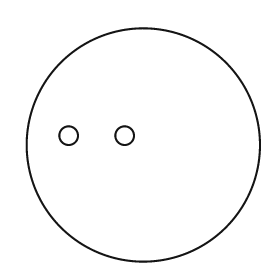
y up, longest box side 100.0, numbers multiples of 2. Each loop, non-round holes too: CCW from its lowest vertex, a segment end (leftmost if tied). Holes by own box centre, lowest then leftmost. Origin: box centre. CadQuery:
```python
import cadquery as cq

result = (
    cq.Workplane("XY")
    .moveTo(0.0, 0.0)
    .circle(50.0)
    .moveTo(-32.0, 4.0)
    .circle(4.0)
    .moveTo(-8.0, 4.0)
    .circle(4.0)
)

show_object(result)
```